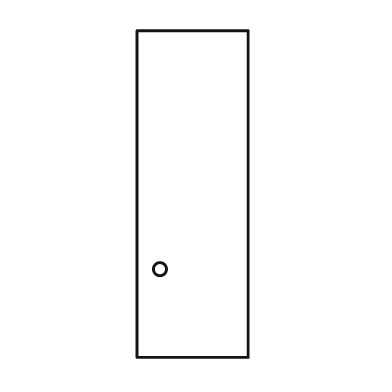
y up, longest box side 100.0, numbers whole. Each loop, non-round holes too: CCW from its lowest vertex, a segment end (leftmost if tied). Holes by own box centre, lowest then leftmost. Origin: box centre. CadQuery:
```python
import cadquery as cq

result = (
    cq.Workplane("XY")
    .moveTo(-17.0, -50.0)
    .lineTo(17.0, -50.0)
    .lineTo(17.0, 50.0)
    .lineTo(-17.0, 50.0)
    .close()
    .moveTo(-10.0, -23.0)
    .circle(2.0)
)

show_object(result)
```